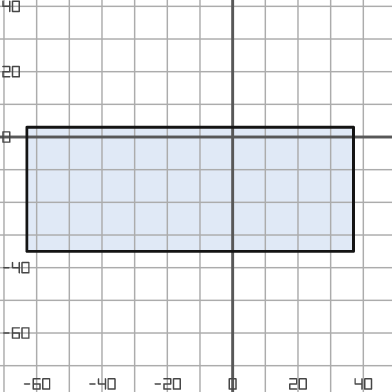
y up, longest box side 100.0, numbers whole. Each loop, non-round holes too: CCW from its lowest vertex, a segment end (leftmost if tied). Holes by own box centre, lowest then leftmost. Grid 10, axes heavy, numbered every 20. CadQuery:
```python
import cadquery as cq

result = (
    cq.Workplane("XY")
    .moveTo(-63.0, -35.0)
    .lineTo(37.0, -35.0)
    .lineTo(37.0, 3.0)
    .lineTo(-63.0, 3.0)
    .close()
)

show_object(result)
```